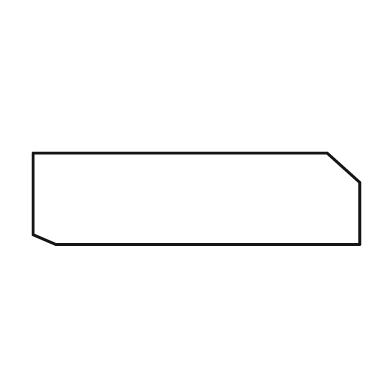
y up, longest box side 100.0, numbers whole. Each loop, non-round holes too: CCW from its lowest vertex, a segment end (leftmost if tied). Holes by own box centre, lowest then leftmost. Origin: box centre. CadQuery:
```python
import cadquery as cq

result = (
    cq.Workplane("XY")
    .moveTo(-43.0, -14.0)
    .lineTo(50.0, -14.0)
    .lineTo(50.0, 5.0)
    .lineTo(40.0, 14.0)
    .lineTo(-50.0, 14.0)
    .lineTo(-50.0, -11.0)
    .close()
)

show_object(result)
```